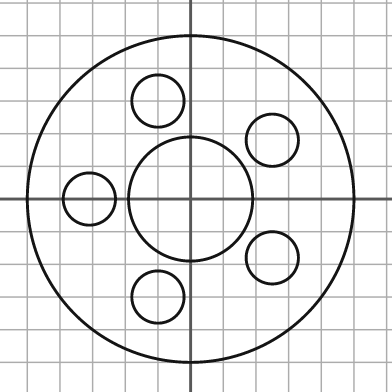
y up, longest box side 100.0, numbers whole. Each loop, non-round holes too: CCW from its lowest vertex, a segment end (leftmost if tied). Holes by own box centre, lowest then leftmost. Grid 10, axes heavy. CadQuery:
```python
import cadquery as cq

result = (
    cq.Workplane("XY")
    .moveTo(0.0, 0.0)
    .circle(50.0)
    .moveTo(-10.0, -30.0)
    .circle(8.0)
    .moveTo(25.0, -18.0)
    .circle(8.0)
    .moveTo(-31.0, 0.0)
    .circle(8.0)
    .moveTo(0.0, 0.0)
    .circle(19.0)
    .moveTo(25.0, 18.0)
    .circle(8.0)
    .moveTo(-10.0, 30.0)
    .circle(8.0)
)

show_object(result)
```